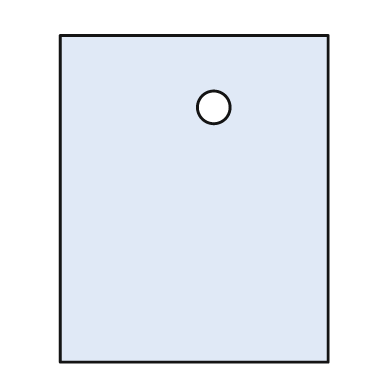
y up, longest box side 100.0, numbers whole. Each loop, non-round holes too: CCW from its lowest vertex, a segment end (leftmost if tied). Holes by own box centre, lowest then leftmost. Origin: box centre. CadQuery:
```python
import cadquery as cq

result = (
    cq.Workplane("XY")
    .moveTo(-41.0, -50.0)
    .lineTo(41.0, -50.0)
    .lineTo(41.0, 50.0)
    .lineTo(-41.0, 50.0)
    .close()
    .moveTo(6.0, 28.0)
    .circle(5.0)
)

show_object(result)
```